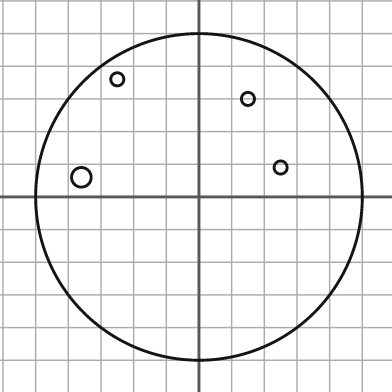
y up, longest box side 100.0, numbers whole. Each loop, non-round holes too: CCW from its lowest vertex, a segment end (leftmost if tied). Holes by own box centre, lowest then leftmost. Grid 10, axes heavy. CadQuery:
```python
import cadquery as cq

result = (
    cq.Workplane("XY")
    .moveTo(0.0, 0.0)
    .circle(50.0)
    .moveTo(-36.0, 6.0)
    .circle(3.0)
    .moveTo(25.0, 9.0)
    .circle(2.0)
    .moveTo(15.0, 30.0)
    .circle(2.0)
    .moveTo(-25.0, 36.0)
    .circle(2.0)
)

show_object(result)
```